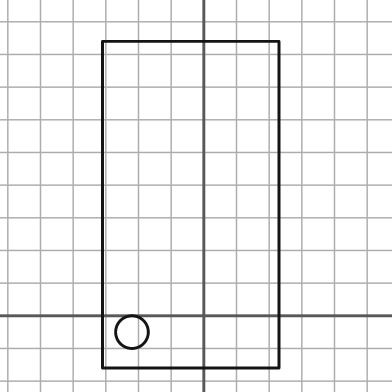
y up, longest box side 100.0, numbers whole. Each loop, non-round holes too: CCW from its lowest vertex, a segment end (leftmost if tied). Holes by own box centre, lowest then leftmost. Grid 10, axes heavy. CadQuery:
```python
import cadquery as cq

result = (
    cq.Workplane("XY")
    .moveTo(-31.0, -16.0)
    .lineTo(23.0, -16.0)
    .lineTo(23.0, 84.0)
    .lineTo(-31.0, 84.0)
    .close()
    .moveTo(-22.0, -5.0)
    .circle(5.0)
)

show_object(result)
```